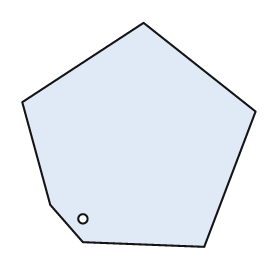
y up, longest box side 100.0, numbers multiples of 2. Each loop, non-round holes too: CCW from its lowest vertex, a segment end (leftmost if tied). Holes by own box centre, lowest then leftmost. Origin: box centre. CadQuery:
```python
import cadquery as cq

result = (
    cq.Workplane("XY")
    .moveTo(28.0, -48.0)
    .lineTo(50.0, 10.0)
    .lineTo(2.0, 48.0)
    .lineTo(-50.0, 14.0)
    .lineTo(-38.0, -30.0)
    .lineTo(-24.0, -46.0)
    .close()
    .moveTo(-24.0, -36.0)
    .circle(2.0)
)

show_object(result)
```